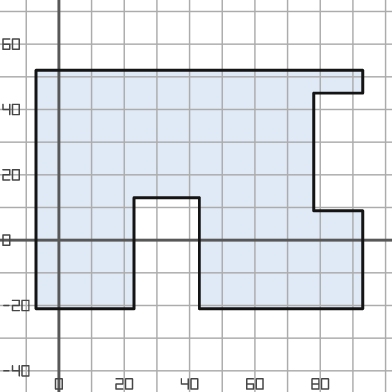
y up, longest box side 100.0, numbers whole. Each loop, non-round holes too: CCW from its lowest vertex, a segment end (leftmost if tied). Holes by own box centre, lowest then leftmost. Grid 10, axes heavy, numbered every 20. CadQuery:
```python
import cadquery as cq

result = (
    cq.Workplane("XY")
    .moveTo(-7.0, -21.0)
    .lineTo(23.0, -21.0)
    .lineTo(23.0, 13.0)
    .lineTo(43.0, 13.0)
    .lineTo(43.0, -21.0)
    .lineTo(93.0, -21.0)
    .lineTo(93.0, 9.0)
    .lineTo(78.0, 9.0)
    .lineTo(78.0, 45.0)
    .lineTo(93.0, 45.0)
    .lineTo(93.0, 52.0)
    .lineTo(-7.0, 52.0)
    .close()
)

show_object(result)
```